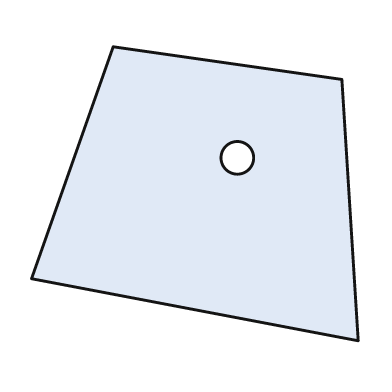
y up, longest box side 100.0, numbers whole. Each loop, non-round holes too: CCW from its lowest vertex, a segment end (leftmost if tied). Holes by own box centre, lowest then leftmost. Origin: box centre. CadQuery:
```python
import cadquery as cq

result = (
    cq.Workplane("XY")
    .moveTo(50.0, -45.0)
    .lineTo(45.0, 35.0)
    .lineTo(-25.0, 45.0)
    .lineTo(-50.0, -26.0)
    .close()
    .moveTo(13.0, 11.0)
    .circle(5.0)
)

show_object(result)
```